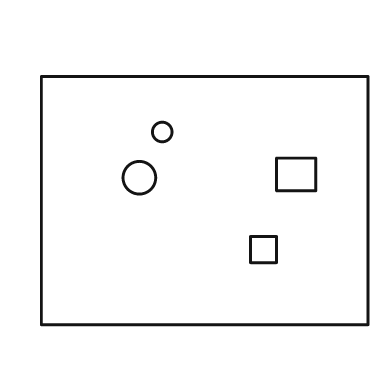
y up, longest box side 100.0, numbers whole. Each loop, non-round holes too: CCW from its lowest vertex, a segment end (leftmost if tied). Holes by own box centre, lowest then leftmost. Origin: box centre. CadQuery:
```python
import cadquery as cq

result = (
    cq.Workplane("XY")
    .moveTo(-50.0, -38.0)
    .lineTo(50.0, -38.0)
    .lineTo(50.0, 38.0)
    .lineTo(-50.0, 38.0)
    .close()
    .moveTo(14.0, -19.0)
    .lineTo(22.0, -19.0)
    .lineTo(22.0, -11.0)
    .lineTo(14.0, -11.0)
    .close()
    .moveTo(-20.0, 7.0)
    .circle(5.0)
    .moveTo(22.0, 3.0)
    .lineTo(34.0, 3.0)
    .lineTo(34.0, 13.0)
    .lineTo(22.0, 13.0)
    .close()
    .moveTo(-13.0, 21.0)
    .circle(3.0)
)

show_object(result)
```